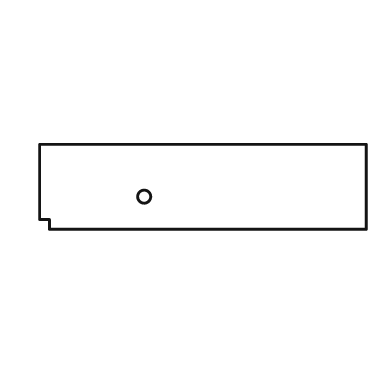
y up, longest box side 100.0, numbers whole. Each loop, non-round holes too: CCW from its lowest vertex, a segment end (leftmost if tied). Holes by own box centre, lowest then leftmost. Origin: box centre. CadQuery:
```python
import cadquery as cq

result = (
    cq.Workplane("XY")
    .moveTo(-47.0, -13.0)
    .lineTo(50.0, -13.0)
    .lineTo(50.0, 13.0)
    .lineTo(-50.0, 13.0)
    .lineTo(-50.0, -10.0)
    .lineTo(-47.0, -10.0)
    .close()
    .moveTo(-18.0, -3.0)
    .circle(2.0)
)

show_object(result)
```